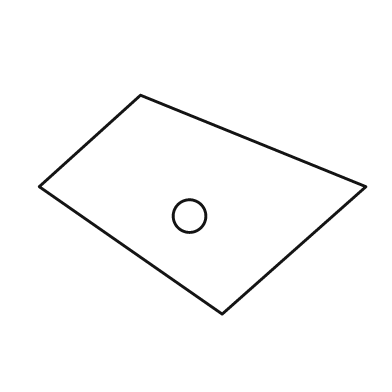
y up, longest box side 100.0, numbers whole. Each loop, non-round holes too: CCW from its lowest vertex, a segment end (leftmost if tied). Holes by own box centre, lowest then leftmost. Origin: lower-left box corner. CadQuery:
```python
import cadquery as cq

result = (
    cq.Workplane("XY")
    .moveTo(56.0, 0.0)
    .lineTo(100.0, 39.0)
    .lineTo(31.0, 67.0)
    .lineTo(0.0, 39.0)
    .close()
    .moveTo(46.0, 30.0)
    .circle(5.0)
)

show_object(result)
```